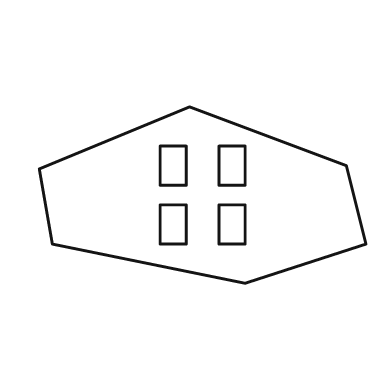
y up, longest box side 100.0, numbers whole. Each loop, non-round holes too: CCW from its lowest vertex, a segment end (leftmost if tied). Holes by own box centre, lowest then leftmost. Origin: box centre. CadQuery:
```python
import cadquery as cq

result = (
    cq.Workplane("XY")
    .moveTo(13.0, -27.0)
    .lineTo(50.0, -15.0)
    .lineTo(44.0, 9.0)
    .lineTo(-4.0, 27.0)
    .lineTo(-50.0, 8.0)
    .lineTo(-46.0, -15.0)
    .close()
    .moveTo(-13.0, -15.0)
    .lineTo(-5.0, -15.0)
    .lineTo(-5.0, -3.0)
    .lineTo(-13.0, -3.0)
    .close()
    .moveTo(5.0, -15.0)
    .lineTo(13.0, -15.0)
    .lineTo(13.0, -3.0)
    .lineTo(5.0, -3.0)
    .close()
    .moveTo(-13.0, 3.0)
    .lineTo(-5.0, 3.0)
    .lineTo(-5.0, 15.0)
    .lineTo(-13.0, 15.0)
    .close()
    .moveTo(5.0, 3.0)
    .lineTo(13.0, 3.0)
    .lineTo(13.0, 15.0)
    .lineTo(5.0, 15.0)
    .close()
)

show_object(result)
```